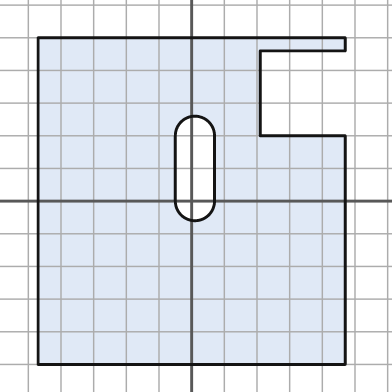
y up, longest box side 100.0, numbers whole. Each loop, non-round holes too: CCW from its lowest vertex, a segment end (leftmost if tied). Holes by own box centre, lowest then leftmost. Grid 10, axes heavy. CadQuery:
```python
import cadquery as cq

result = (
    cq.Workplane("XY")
    .moveTo(-47.0, -50.0)
    .lineTo(47.0, -50.0)
    .lineTo(47.0, 20.0)
    .lineTo(21.0, 20.0)
    .lineTo(21.0, 46.0)
    .lineTo(47.0, 46.0)
    .lineTo(47.0, 50.0)
    .lineTo(-47.0, 50.0)
    .close()
    .moveTo(-5.0, 0.0)
    .threePointArc((1.0, -6.0), (7.0, 0.0))
    .lineTo(7.0, 20.0)
    .threePointArc((1.0, 26.0), (-5.0, 20.0))
    .close()
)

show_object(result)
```